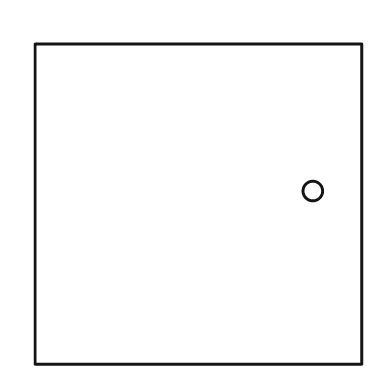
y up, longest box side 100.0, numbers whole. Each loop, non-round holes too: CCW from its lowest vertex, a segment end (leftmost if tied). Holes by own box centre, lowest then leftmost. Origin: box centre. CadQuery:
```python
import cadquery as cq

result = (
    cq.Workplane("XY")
    .moveTo(-50.0, -49.0)
    .lineTo(50.0, -49.0)
    .lineTo(50.0, 49.0)
    .lineTo(-50.0, 49.0)
    .close()
    .moveTo(35.0, 4.0)
    .circle(3.0)
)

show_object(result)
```